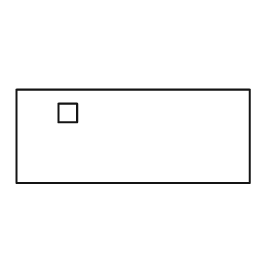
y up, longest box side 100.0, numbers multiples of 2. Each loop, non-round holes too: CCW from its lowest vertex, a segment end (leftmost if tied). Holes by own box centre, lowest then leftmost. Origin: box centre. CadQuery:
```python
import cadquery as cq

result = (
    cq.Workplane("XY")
    .moveTo(-50.0, -20.0)
    .lineTo(50.0, -20.0)
    .lineTo(50.0, 20.0)
    .lineTo(-50.0, 20.0)
    .close()
    .moveTo(-32.0, 6.0)
    .lineTo(-24.0, 6.0)
    .lineTo(-24.0, 14.0)
    .lineTo(-32.0, 14.0)
    .close()
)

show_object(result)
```